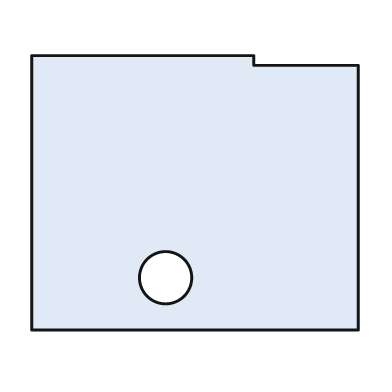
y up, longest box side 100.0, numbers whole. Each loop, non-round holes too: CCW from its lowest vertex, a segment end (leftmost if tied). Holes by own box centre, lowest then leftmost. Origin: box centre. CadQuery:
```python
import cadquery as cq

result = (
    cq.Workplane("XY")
    .moveTo(-50.0, -42.0)
    .lineTo(50.0, -42.0)
    .lineTo(50.0, 39.0)
    .lineTo(18.0, 39.0)
    .lineTo(18.0, 42.0)
    .lineTo(-50.0, 42.0)
    .close()
    .moveTo(-9.0, -26.0)
    .circle(8.0)
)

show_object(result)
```